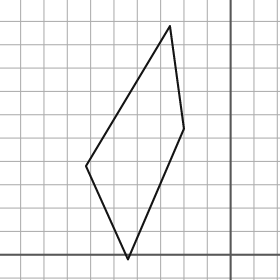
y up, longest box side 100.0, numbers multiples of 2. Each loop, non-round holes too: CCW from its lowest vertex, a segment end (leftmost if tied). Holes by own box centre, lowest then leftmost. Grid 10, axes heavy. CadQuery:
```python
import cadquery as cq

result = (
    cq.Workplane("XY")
    .moveTo(-44.0, -2.0)
    .lineTo(-20.0, 54.0)
    .lineTo(-26.0, 98.0)
    .lineTo(-62.0, 38.0)
    .close()
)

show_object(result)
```